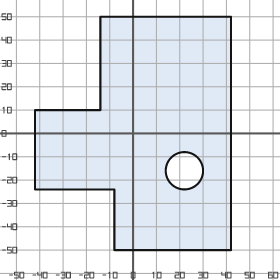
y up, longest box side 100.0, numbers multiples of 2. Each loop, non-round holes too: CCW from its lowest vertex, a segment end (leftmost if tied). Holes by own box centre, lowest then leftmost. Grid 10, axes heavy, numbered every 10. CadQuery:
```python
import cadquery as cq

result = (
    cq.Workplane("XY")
    .moveTo(-8.0, -50.0)
    .lineTo(42.0, -50.0)
    .lineTo(42.0, 50.0)
    .lineTo(-14.0, 50.0)
    .lineTo(-14.0, 10.0)
    .lineTo(-42.0, 10.0)
    .lineTo(-42.0, -24.0)
    .lineTo(-8.0, -24.0)
    .close()
    .moveTo(22.0, -16.0)
    .circle(8.0)
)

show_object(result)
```